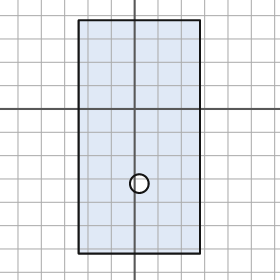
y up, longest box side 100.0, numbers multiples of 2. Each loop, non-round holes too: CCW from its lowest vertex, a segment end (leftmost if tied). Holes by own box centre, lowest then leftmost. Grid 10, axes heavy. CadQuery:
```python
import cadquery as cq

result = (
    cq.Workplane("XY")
    .moveTo(-24.0, -62.0)
    .lineTo(28.0, -62.0)
    .lineTo(28.0, 38.0)
    .lineTo(-24.0, 38.0)
    .close()
    .moveTo(2.0, -32.0)
    .circle(4.0)
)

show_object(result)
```